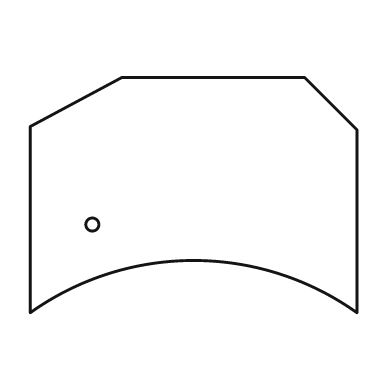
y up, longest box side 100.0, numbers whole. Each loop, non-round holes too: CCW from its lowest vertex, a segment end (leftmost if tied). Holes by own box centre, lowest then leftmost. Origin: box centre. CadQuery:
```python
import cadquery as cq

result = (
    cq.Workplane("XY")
    .moveTo(-50.0, -36.0)
    .threePointArc((0.0, -20.0), (50.0, -36.0))
    .lineTo(50.0, 20.0)
    .lineTo(34.0, 36.0)
    .lineTo(-22.0, 36.0)
    .lineTo(-50.0, 21.0)
    .close()
    .moveTo(-31.0, -9.0)
    .circle(2.0)
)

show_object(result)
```